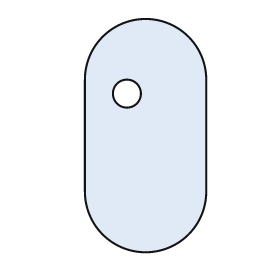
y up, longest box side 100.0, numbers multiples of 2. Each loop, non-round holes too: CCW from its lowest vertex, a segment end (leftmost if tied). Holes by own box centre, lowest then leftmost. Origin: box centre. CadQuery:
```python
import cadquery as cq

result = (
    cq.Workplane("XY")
    .moveTo(-26.0, -24.0)
    .threePointArc((0.0, -50.0), (26.0, -24.0))
    .lineTo(26.0, 24.0)
    .threePointArc((0.0, 50.0), (-26.0, 24.0))
    .close()
    .moveTo(-8.0, 18.0)
    .circle(6.0)
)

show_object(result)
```